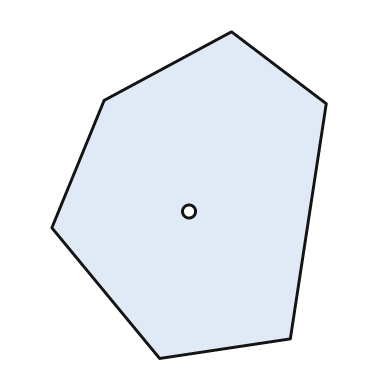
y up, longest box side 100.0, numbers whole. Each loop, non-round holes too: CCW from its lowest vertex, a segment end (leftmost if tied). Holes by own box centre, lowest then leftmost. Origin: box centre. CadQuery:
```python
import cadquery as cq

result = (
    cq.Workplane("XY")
    .moveTo(-9.0, -50.0)
    .lineTo(31.0, -44.0)
    .lineTo(42.0, 28.0)
    .lineTo(13.0, 50.0)
    .lineTo(-26.0, 29.0)
    .lineTo(-42.0, -10.0)
    .close()
    .moveTo(0.0, -5.0)
    .circle(2.0)
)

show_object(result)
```